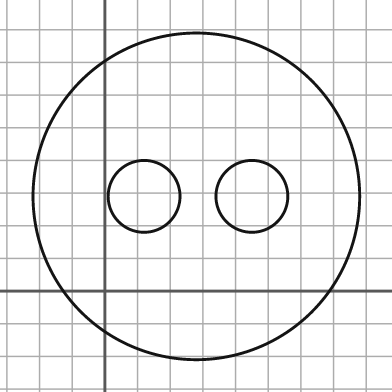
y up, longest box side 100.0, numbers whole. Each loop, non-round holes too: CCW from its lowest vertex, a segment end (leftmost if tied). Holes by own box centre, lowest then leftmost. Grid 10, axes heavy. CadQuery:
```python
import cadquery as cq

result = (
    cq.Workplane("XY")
    .moveTo(28.0, 29.0)
    .circle(50.0)
    .moveTo(12.0, 29.0)
    .circle(11.0)
    .moveTo(45.0, 29.0)
    .circle(11.0)
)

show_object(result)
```